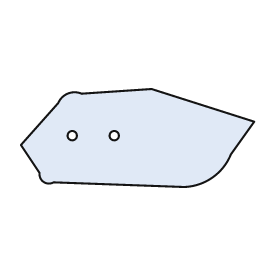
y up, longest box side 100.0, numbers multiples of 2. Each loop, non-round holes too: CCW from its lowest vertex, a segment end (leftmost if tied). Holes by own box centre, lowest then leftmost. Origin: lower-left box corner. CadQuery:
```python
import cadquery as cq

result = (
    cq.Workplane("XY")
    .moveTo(70.0, 0.0)
    .threePointArc((82.0, 4.0), (90.0, 14.0))
    .lineTo(100.0, 28.0)
    .lineTo(56.0, 42.0)
    .lineTo(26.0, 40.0)
    .threePointArc((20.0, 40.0), (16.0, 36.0))
    .lineTo(0.0, 18.0)
    .lineTo(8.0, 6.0)
    .threePointArc((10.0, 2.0), (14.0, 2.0))
    .close()
    .moveTo(22.0, 22.0)
    .circle(2.0)
    .moveTo(40.0, 22.0)
    .circle(2.0)
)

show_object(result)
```